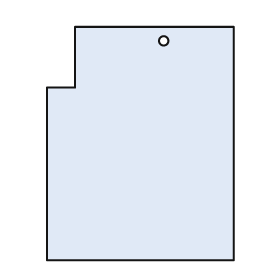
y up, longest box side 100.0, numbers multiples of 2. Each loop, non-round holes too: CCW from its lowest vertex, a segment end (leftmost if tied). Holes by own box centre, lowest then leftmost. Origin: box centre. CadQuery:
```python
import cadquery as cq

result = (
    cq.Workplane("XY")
    .moveTo(-40.0, -50.0)
    .lineTo(40.0, -50.0)
    .lineTo(40.0, 50.0)
    .lineTo(-28.0, 50.0)
    .lineTo(-28.0, 24.0)
    .lineTo(-40.0, 24.0)
    .close()
    .moveTo(10.0, 44.0)
    .circle(2.0)
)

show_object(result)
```